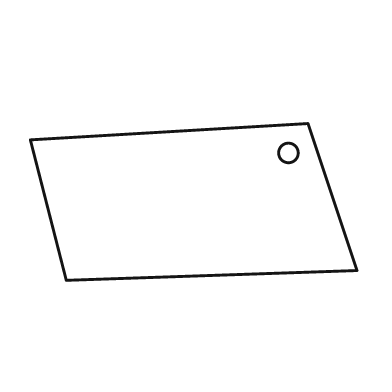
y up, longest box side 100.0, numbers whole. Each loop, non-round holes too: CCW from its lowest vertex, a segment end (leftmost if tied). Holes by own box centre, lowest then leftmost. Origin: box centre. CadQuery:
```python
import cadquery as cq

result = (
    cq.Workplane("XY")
    .moveTo(-39.0, -24.0)
    .lineTo(50.0, -21.0)
    .lineTo(35.0, 24.0)
    .lineTo(-50.0, 19.0)
    .close()
    .moveTo(29.0, 15.0)
    .circle(3.0)
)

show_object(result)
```